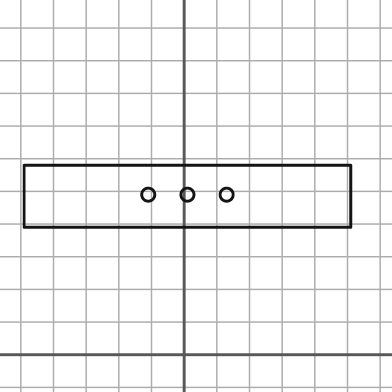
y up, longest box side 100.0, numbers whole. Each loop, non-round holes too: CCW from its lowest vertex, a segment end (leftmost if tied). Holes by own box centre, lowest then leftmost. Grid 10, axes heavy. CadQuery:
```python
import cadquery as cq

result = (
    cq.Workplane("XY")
    .moveTo(-49.0, 39.0)
    .lineTo(51.0, 39.0)
    .lineTo(51.0, 58.0)
    .lineTo(-49.0, 58.0)
    .close()
    .moveTo(-11.0, 49.0)
    .circle(2.0)
    .moveTo(1.0, 49.0)
    .circle(2.0)
    .moveTo(13.0, 49.0)
    .circle(2.0)
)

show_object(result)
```